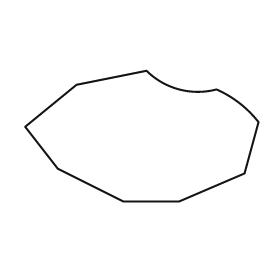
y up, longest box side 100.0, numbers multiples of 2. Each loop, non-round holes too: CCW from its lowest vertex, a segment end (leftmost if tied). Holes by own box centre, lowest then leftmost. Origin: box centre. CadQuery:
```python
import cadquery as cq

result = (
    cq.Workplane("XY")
    .moveTo(-8.0, -28.0)
    .lineTo(16.0, -28.0)
    .lineTo(44.0, -16.0)
    .lineTo(50.0, 6.0)
    .threePointArc((42.0, 14.0), (32.0, 20.0))
    .threePointArc((16.0, 20.0), (2.0, 28.0))
    .lineTo(-28.0, 22.0)
    .lineTo(-50.0, 4.0)
    .lineTo(-36.0, -14.0)
    .close()
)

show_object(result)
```